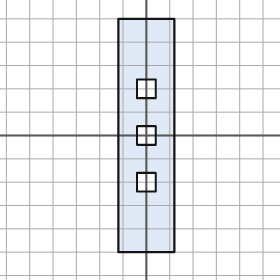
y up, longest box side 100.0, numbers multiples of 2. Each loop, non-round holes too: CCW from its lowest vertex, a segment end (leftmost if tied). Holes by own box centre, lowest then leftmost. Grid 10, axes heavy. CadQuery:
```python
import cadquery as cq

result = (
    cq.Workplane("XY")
    .moveTo(-12.0, -50.0)
    .lineTo(12.0, -50.0)
    .lineTo(12.0, 50.0)
    .lineTo(-12.0, 50.0)
    .close()
    .moveTo(-4.0, -24.0)
    .lineTo(4.0, -24.0)
    .lineTo(4.0, -16.0)
    .lineTo(-4.0, -16.0)
    .close()
    .moveTo(-4.0, -4.0)
    .lineTo(4.0, -4.0)
    .lineTo(4.0, 4.0)
    .lineTo(-4.0, 4.0)
    .close()
    .moveTo(-4.0, 16.0)
    .lineTo(4.0, 16.0)
    .lineTo(4.0, 24.0)
    .lineTo(-4.0, 24.0)
    .close()
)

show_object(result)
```